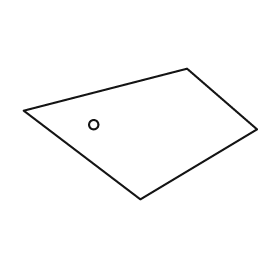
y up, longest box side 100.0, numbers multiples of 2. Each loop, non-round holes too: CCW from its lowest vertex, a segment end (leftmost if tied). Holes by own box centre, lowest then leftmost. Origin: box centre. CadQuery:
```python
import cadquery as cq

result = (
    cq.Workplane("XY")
    .moveTo(0.0, -28.0)
    .lineTo(50.0, 2.0)
    .lineTo(20.0, 28.0)
    .lineTo(-50.0, 10.0)
    .close()
    .moveTo(-20.0, 4.0)
    .circle(2.0)
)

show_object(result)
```